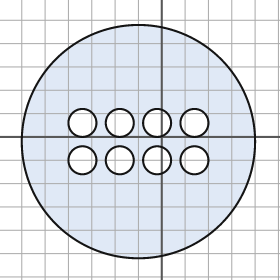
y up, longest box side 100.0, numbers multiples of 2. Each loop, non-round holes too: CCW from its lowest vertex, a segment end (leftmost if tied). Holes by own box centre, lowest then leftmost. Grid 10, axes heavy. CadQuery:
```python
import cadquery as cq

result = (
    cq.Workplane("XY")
    .moveTo(-10.0, -2.0)
    .circle(50.0)
    .moveTo(-34.0, -10.0)
    .circle(6.0)
    .moveTo(-18.0, -10.0)
    .circle(6.0)
    .moveTo(-2.0, -10.0)
    .circle(6.0)
    .moveTo(14.0, -10.0)
    .circle(6.0)
    .moveTo(-34.0, 6.0)
    .circle(6.0)
    .moveTo(-18.0, 6.0)
    .circle(6.0)
    .moveTo(-2.0, 6.0)
    .circle(6.0)
    .moveTo(14.0, 6.0)
    .circle(6.0)
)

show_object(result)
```